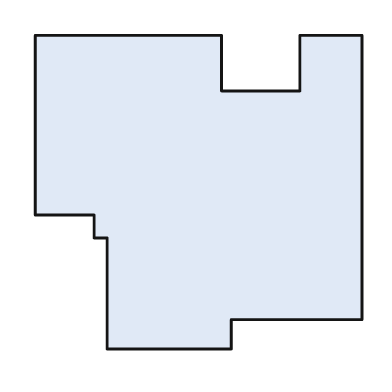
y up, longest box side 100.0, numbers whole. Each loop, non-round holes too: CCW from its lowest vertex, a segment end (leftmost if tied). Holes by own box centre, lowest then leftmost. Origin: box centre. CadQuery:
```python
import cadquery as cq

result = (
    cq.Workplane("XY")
    .moveTo(-28.0, -48.0)
    .lineTo(10.0, -48.0)
    .lineTo(10.0, -39.0)
    .lineTo(50.0, -39.0)
    .lineTo(50.0, 48.0)
    .lineTo(31.0, 48.0)
    .lineTo(31.0, 31.0)
    .lineTo(7.0, 31.0)
    .lineTo(7.0, 48.0)
    .lineTo(-50.0, 48.0)
    .lineTo(-50.0, -7.0)
    .lineTo(-32.0, -7.0)
    .lineTo(-32.0, -14.0)
    .lineTo(-28.0, -14.0)
    .close()
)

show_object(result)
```